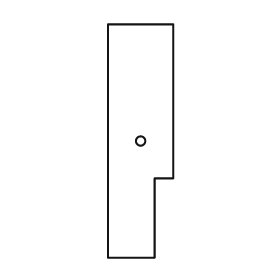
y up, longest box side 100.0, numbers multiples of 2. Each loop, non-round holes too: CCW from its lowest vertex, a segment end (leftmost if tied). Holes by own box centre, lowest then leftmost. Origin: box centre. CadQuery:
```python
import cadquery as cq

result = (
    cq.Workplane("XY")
    .moveTo(-14.0, -50.0)
    .lineTo(6.0, -50.0)
    .lineTo(6.0, -16.0)
    .lineTo(14.0, -16.0)
    .lineTo(14.0, 50.0)
    .lineTo(-14.0, 50.0)
    .close()
    .moveTo(0.0, 0.0)
    .circle(2.0)
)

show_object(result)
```